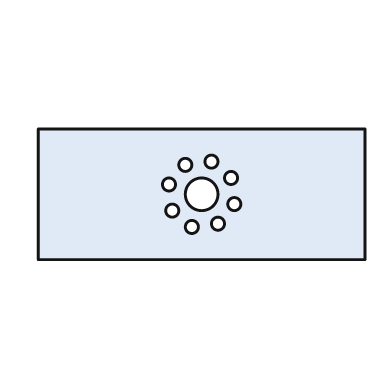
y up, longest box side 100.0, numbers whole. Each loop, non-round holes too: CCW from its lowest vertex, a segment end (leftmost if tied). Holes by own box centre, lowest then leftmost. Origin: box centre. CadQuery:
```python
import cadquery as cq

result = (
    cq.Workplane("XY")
    .moveTo(-50.0, -20.0)
    .lineTo(50.0, -20.0)
    .lineTo(50.0, 20.0)
    .lineTo(-50.0, 20.0)
    .close()
    .moveTo(-3.0, -10.0)
    .circle(2.0)
    .moveTo(5.0, -9.0)
    .circle(2.0)
    .moveTo(-9.0, -5.0)
    .circle(2.0)
    .moveTo(10.0, -3.0)
    .circle(2.0)
    .moveTo(0.0, 0.0)
    .circle(5.0)
    .moveTo(-10.0, 3.0)
    .circle(2.0)
    .moveTo(9.0, 5.0)
    .circle(2.0)
    .moveTo(-5.0, 9.0)
    .circle(2.0)
    .moveTo(3.0, 10.0)
    .circle(2.0)
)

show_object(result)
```